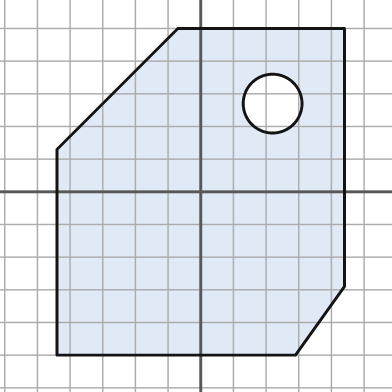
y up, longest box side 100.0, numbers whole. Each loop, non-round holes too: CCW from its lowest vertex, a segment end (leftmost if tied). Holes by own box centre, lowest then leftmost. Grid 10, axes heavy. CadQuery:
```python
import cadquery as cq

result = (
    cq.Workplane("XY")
    .moveTo(-44.0, -50.0)
    .lineTo(29.0, -50.0)
    .lineTo(44.0, -29.0)
    .lineTo(44.0, 50.0)
    .lineTo(-7.0, 50.0)
    .lineTo(-44.0, 13.0)
    .close()
    .moveTo(22.0, 27.0)
    .circle(9.0)
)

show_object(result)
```